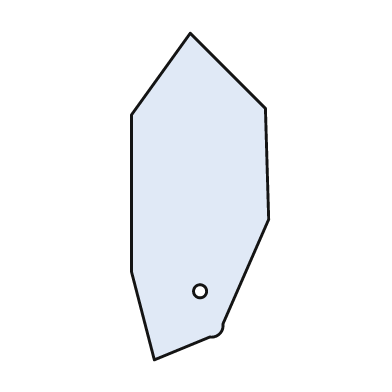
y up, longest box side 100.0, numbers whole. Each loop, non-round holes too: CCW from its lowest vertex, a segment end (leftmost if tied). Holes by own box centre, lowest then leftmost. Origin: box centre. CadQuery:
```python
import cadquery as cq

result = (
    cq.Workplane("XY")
    .moveTo(-14.0, -50.0)
    .lineTo(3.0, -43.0)
    .threePointArc((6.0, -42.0), (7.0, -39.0))
    .lineTo(21.0, -7.0)
    .lineTo(20.0, 27.0)
    .lineTo(-3.0, 50.0)
    .lineTo(-21.0, 25.0)
    .lineTo(-21.0, -23.0)
    .close()
    .moveTo(0.0, -29.0)
    .circle(2.0)
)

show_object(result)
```